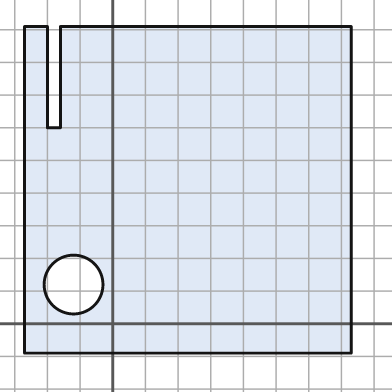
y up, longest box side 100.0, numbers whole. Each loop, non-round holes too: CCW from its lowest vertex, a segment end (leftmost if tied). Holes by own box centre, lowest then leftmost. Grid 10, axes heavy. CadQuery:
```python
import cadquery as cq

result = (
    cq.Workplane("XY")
    .moveTo(-27.0, -9.0)
    .lineTo(73.0, -9.0)
    .lineTo(73.0, 91.0)
    .lineTo(-16.0, 91.0)
    .lineTo(-16.0, 60.0)
    .lineTo(-20.0, 60.0)
    .lineTo(-20.0, 91.0)
    .lineTo(-27.0, 91.0)
    .close()
    .moveTo(-12.0, 12.0)
    .circle(9.0)
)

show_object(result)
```